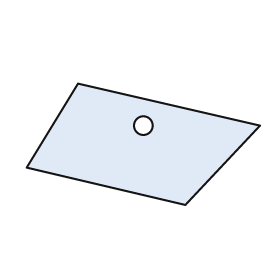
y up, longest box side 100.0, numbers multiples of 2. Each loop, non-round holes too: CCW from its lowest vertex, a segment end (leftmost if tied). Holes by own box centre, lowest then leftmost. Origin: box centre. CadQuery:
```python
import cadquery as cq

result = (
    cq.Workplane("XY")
    .moveTo(18.0, -26.0)
    .lineTo(50.0, 8.0)
    .lineTo(-28.0, 26.0)
    .lineTo(-50.0, -10.0)
    .close()
    .moveTo(0.0, 8.0)
    .circle(4.0)
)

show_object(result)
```